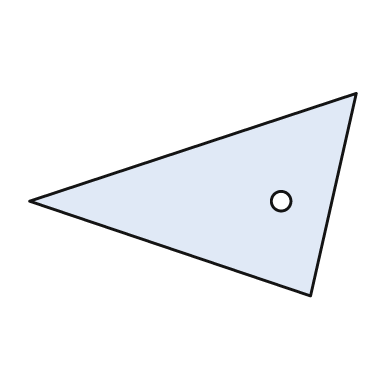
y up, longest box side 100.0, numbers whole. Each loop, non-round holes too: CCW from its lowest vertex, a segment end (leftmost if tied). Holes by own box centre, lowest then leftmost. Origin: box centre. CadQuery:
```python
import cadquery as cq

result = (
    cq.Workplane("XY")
    .moveTo(36.0, -31.0)
    .lineTo(50.0, 31.0)
    .lineTo(-50.0, -2.0)
    .close()
    .moveTo(27.0, -2.0)
    .circle(3.0)
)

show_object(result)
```